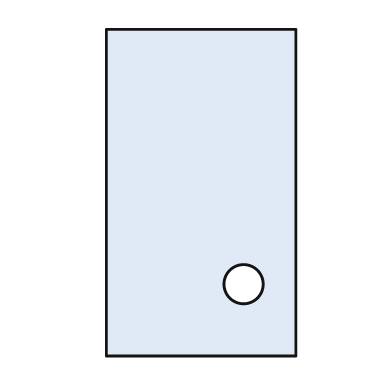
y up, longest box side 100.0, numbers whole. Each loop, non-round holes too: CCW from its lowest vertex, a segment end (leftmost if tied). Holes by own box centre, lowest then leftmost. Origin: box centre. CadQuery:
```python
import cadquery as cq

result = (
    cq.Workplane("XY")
    .moveTo(-29.0, -50.0)
    .lineTo(29.0, -50.0)
    .lineTo(29.0, 50.0)
    .lineTo(-29.0, 50.0)
    .close()
    .moveTo(13.0, -28.0)
    .circle(6.0)
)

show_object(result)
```